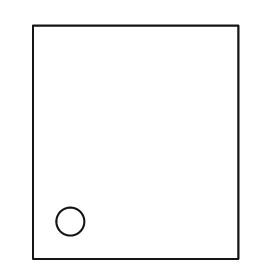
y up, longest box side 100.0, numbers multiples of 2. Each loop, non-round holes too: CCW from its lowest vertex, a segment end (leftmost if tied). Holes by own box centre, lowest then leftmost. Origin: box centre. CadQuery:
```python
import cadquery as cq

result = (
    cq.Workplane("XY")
    .moveTo(-44.0, -50.0)
    .lineTo(44.0, -50.0)
    .lineTo(44.0, 50.0)
    .lineTo(-44.0, 50.0)
    .close()
    .moveTo(-28.0, -34.0)
    .circle(6.0)
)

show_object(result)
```